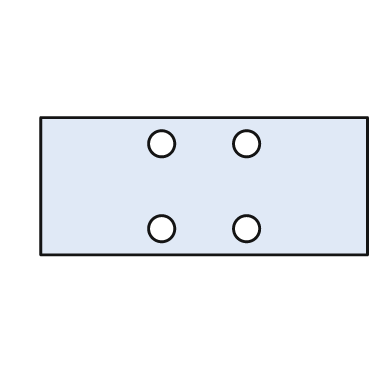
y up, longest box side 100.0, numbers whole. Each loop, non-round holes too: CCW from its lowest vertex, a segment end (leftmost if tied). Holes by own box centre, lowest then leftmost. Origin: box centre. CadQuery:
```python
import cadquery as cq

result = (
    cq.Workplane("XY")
    .moveTo(-50.0, -21.0)
    .lineTo(50.0, -21.0)
    .lineTo(50.0, 21.0)
    .lineTo(-50.0, 21.0)
    .close()
    .moveTo(-13.0, -13.0)
    .circle(4.0)
    .moveTo(13.0, -13.0)
    .circle(4.0)
    .moveTo(-13.0, 13.0)
    .circle(4.0)
    .moveTo(13.0, 13.0)
    .circle(4.0)
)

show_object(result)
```